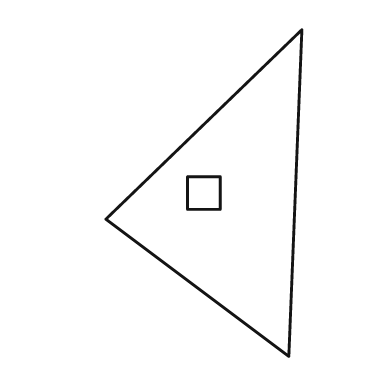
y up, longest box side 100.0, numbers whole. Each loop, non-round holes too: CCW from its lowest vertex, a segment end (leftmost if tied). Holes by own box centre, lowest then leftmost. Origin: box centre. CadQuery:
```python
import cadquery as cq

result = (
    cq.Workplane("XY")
    .moveTo(26.0, -50.0)
    .lineTo(30.0, 50.0)
    .lineTo(-30.0, -8.0)
    .close()
    .moveTo(-5.0, -5.0)
    .lineTo(5.0, -5.0)
    .lineTo(5.0, 5.0)
    .lineTo(-5.0, 5.0)
    .close()
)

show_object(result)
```